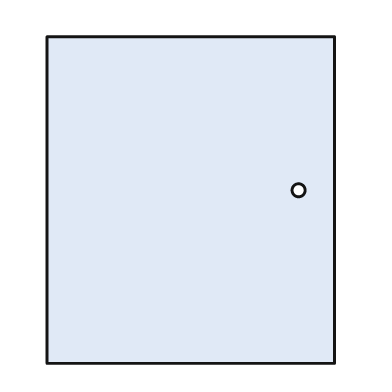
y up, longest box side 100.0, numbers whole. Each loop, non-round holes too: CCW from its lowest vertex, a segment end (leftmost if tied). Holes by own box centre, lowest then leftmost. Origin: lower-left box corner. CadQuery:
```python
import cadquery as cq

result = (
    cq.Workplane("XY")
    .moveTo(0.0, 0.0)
    .lineTo(88.0, 0.0)
    .lineTo(88.0, 100.0)
    .lineTo(0.0, 100.0)
    .close()
    .moveTo(77.0, 53.0)
    .circle(2.0)
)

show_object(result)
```